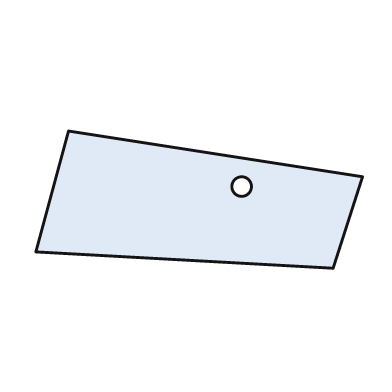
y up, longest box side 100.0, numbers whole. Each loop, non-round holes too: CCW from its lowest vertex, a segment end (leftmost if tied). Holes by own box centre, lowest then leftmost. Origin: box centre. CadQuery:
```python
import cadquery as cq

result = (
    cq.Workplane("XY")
    .moveTo(41.0, -21.0)
    .lineTo(50.0, 7.0)
    .lineTo(-40.0, 21.0)
    .lineTo(-50.0, -16.0)
    .close()
    .moveTo(13.0, 4.0)
    .circle(3.0)
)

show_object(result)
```